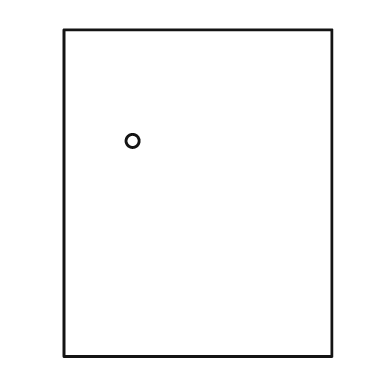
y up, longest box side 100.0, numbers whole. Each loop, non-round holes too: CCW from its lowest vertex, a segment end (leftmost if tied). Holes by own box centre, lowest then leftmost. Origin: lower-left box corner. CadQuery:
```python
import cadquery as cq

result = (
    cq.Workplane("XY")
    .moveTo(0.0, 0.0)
    .lineTo(82.0, 0.0)
    .lineTo(82.0, 100.0)
    .lineTo(0.0, 100.0)
    .close()
    .moveTo(21.0, 66.0)
    .circle(2.0)
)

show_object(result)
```